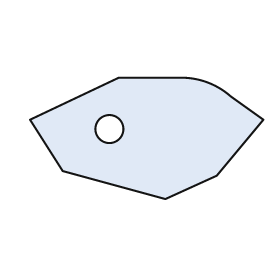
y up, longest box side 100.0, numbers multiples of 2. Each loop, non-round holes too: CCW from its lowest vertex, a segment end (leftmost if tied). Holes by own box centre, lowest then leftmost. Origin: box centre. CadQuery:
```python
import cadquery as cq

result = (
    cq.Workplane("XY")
    .moveTo(8.0, -26.0)
    .lineTo(30.0, -16.0)
    .lineTo(50.0, 8.0)
    .lineTo(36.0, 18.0)
    .threePointArc((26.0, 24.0), (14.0, 26.0))
    .lineTo(-12.0, 26.0)
    .lineTo(-50.0, 8.0)
    .lineTo(-36.0, -14.0)
    .close()
    .moveTo(-16.0, 4.0)
    .circle(6.0)
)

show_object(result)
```